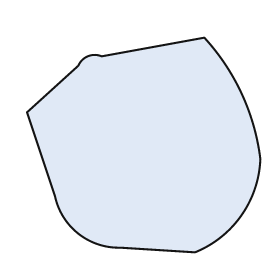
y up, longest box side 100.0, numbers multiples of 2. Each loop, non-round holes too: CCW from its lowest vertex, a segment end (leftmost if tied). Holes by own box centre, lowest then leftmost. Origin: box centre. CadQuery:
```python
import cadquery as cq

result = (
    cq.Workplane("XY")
    .moveTo(22.0, -46.0)
    .threePointArc((42.0, -30.0), (50.0, -6.0))
    .threePointArc((42.0, 22.0), (26.0, 46.0))
    .lineTo(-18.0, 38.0)
    .threePointArc((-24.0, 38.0), (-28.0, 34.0))
    .lineTo(-50.0, 14.0)
    .lineTo(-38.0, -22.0)
    .threePointArc((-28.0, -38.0), (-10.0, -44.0))
    .close()
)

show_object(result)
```